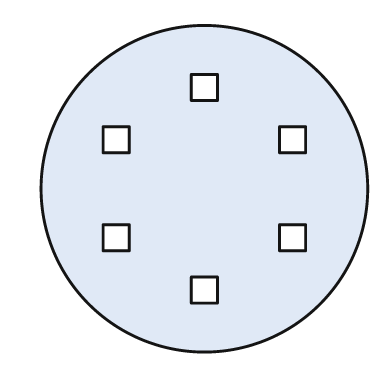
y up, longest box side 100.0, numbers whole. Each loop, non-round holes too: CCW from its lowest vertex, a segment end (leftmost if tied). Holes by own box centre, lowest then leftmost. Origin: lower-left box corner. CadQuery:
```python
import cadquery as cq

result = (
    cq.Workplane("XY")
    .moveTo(50.0, 50.0)
    .circle(50.0)
    .moveTo(46.0, 15.0)
    .lineTo(54.0, 15.0)
    .lineTo(54.0, 23.0)
    .lineTo(46.0, 23.0)
    .close()
    .moveTo(19.0, 31.0)
    .lineTo(27.0, 31.0)
    .lineTo(27.0, 39.0)
    .lineTo(19.0, 39.0)
    .close()
    .moveTo(73.0, 31.0)
    .lineTo(81.0, 31.0)
    .lineTo(81.0, 39.0)
    .lineTo(73.0, 39.0)
    .close()
    .moveTo(19.0, 61.0)
    .lineTo(27.0, 61.0)
    .lineTo(27.0, 69.0)
    .lineTo(19.0, 69.0)
    .close()
    .moveTo(73.0, 61.0)
    .lineTo(81.0, 61.0)
    .lineTo(81.0, 69.0)
    .lineTo(73.0, 69.0)
    .close()
    .moveTo(46.0, 77.0)
    .lineTo(54.0, 77.0)
    .lineTo(54.0, 85.0)
    .lineTo(46.0, 85.0)
    .close()
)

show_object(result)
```